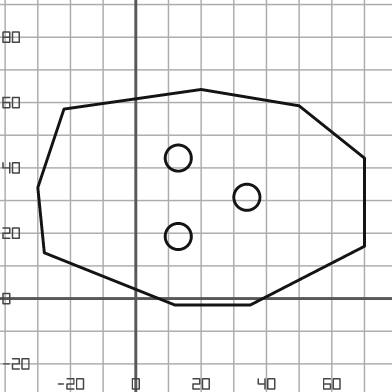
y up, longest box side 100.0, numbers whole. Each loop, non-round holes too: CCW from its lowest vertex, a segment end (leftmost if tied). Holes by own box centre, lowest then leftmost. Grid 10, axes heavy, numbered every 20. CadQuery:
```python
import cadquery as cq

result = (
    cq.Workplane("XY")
    .moveTo(12.0, -2.0)
    .lineTo(35.0, -2.0)
    .lineTo(70.0, 16.0)
    .lineTo(70.0, 43.0)
    .lineTo(50.0, 59.0)
    .lineTo(20.0, 64.0)
    .lineTo(-22.0, 58.0)
    .lineTo(-30.0, 34.0)
    .lineTo(-28.0, 14.0)
    .close()
    .moveTo(13.0, 19.0)
    .circle(4.0)
    .moveTo(34.0, 31.0)
    .circle(4.0)
    .moveTo(13.0, 43.0)
    .circle(4.0)
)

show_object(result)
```